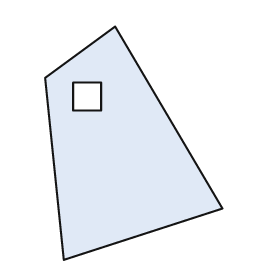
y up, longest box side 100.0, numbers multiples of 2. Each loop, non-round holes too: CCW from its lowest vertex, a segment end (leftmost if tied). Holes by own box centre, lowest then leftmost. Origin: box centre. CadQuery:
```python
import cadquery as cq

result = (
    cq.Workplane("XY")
    .moveTo(-30.0, -50.0)
    .lineTo(38.0, -28.0)
    .lineTo(-8.0, 50.0)
    .lineTo(-38.0, 28.0)
    .close()
    .moveTo(-26.0, 14.0)
    .lineTo(-14.0, 14.0)
    .lineTo(-14.0, 26.0)
    .lineTo(-26.0, 26.0)
    .close()
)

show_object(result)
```